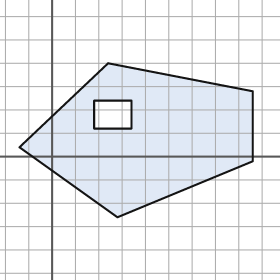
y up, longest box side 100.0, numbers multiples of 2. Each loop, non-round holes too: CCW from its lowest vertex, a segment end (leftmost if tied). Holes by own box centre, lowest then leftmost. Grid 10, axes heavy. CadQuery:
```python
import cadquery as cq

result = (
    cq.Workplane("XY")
    .moveTo(28.0, -26.0)
    .lineTo(86.0, -2.0)
    .lineTo(86.0, 28.0)
    .lineTo(24.0, 40.0)
    .lineTo(-14.0, 4.0)
    .close()
    .moveTo(18.0, 12.0)
    .lineTo(34.0, 12.0)
    .lineTo(34.0, 24.0)
    .lineTo(18.0, 24.0)
    .close()
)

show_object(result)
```